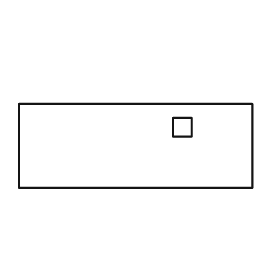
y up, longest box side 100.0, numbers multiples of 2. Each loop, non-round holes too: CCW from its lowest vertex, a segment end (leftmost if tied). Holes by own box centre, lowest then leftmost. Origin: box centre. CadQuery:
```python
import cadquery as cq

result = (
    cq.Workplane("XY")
    .moveTo(-50.0, -18.0)
    .lineTo(50.0, -18.0)
    .lineTo(50.0, 18.0)
    .lineTo(-50.0, 18.0)
    .close()
    .moveTo(16.0, 4.0)
    .lineTo(24.0, 4.0)
    .lineTo(24.0, 12.0)
    .lineTo(16.0, 12.0)
    .close()
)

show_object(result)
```